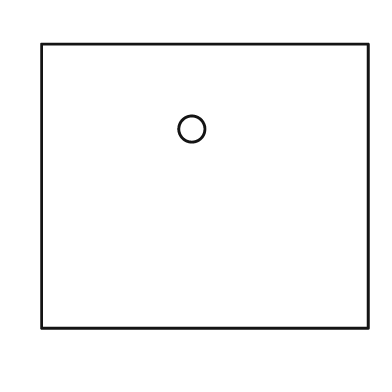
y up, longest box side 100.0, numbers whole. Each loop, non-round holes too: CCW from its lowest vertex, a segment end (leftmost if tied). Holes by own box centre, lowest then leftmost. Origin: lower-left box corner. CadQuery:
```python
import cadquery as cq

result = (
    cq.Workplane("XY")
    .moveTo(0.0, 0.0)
    .lineTo(100.0, 0.0)
    .lineTo(100.0, 87.0)
    .lineTo(0.0, 87.0)
    .close()
    .moveTo(46.0, 61.0)
    .circle(4.0)
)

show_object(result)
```